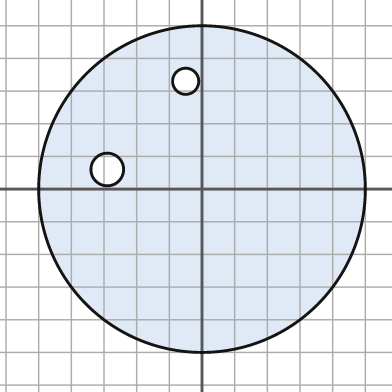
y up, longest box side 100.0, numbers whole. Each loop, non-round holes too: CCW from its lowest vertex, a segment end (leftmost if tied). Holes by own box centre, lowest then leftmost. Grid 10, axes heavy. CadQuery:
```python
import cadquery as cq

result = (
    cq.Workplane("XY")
    .moveTo(0.0, 0.0)
    .circle(50.0)
    .moveTo(-29.0, 6.0)
    .circle(5.0)
    .moveTo(-5.0, 33.0)
    .circle(4.0)
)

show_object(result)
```